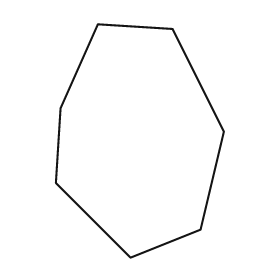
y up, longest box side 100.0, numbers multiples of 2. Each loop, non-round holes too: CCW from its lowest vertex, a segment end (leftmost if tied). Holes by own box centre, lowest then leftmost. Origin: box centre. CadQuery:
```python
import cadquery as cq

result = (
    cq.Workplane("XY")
    .moveTo(-4.0, -50.0)
    .lineTo(26.0, -38.0)
    .lineTo(36.0, 4.0)
    .lineTo(14.0, 48.0)
    .lineTo(-18.0, 50.0)
    .lineTo(-34.0, 14.0)
    .lineTo(-36.0, -18.0)
    .close()
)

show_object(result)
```